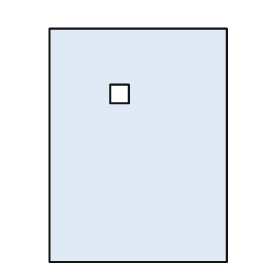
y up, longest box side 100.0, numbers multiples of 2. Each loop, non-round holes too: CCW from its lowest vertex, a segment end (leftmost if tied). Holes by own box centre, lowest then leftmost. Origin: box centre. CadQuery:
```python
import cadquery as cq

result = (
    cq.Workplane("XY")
    .moveTo(-38.0, -50.0)
    .lineTo(38.0, -50.0)
    .lineTo(38.0, 50.0)
    .lineTo(-38.0, 50.0)
    .close()
    .moveTo(-12.0, 18.0)
    .lineTo(-4.0, 18.0)
    .lineTo(-4.0, 26.0)
    .lineTo(-12.0, 26.0)
    .close()
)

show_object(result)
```